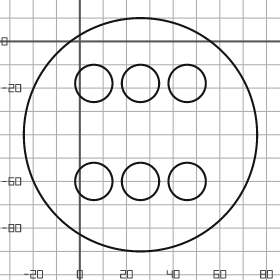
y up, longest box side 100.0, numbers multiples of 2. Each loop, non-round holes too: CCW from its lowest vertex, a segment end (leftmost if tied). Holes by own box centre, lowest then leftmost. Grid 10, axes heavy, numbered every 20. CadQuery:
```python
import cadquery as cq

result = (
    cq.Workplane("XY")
    .moveTo(26.0, -40.0)
    .circle(50.0)
    .moveTo(6.0, -60.0)
    .circle(8.0)
    .moveTo(26.0, -60.0)
    .circle(8.0)
    .moveTo(46.0, -60.0)
    .circle(8.0)
    .moveTo(6.0, -18.0)
    .circle(8.0)
    .moveTo(26.0, -18.0)
    .circle(8.0)
    .moveTo(46.0, -18.0)
    .circle(8.0)
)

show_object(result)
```